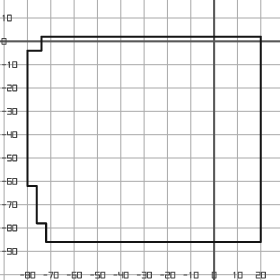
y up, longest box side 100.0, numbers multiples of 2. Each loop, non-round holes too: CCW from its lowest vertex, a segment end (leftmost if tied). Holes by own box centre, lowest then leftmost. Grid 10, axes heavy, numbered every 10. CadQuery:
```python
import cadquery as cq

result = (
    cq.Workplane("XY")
    .moveTo(-72.0, -86.0)
    .lineTo(20.0, -86.0)
    .lineTo(20.0, 2.0)
    .lineTo(-74.0, 2.0)
    .lineTo(-74.0, -4.0)
    .lineTo(-80.0, -4.0)
    .lineTo(-80.0, -62.0)
    .lineTo(-76.0, -62.0)
    .lineTo(-76.0, -78.0)
    .lineTo(-72.0, -78.0)
    .close()
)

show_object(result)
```